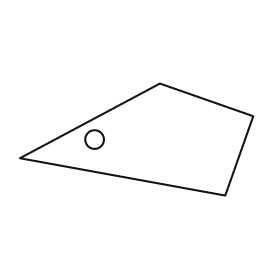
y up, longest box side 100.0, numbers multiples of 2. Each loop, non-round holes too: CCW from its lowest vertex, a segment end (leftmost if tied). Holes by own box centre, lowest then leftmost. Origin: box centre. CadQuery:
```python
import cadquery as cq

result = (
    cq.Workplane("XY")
    .moveTo(38.0, -24.0)
    .lineTo(50.0, 10.0)
    .lineTo(10.0, 24.0)
    .lineTo(-50.0, -8.0)
    .close()
    .moveTo(-18.0, 0.0)
    .circle(4.0)
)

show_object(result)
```